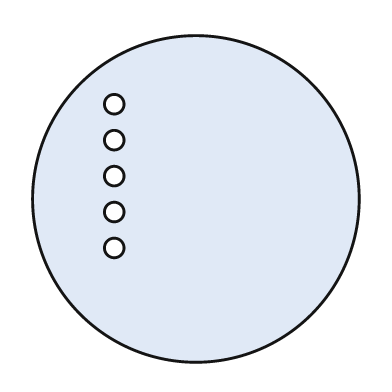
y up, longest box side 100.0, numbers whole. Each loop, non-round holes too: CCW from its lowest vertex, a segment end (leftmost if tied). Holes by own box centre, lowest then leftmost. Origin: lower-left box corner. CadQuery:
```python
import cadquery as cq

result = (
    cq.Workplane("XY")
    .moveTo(50.0, 50.0)
    .circle(50.0)
    .moveTo(25.0, 35.0)
    .circle(3.0)
    .moveTo(25.0, 46.0)
    .circle(3.0)
    .moveTo(25.0, 57.0)
    .circle(3.0)
    .moveTo(25.0, 68.0)
    .circle(3.0)
    .moveTo(25.0, 79.0)
    .circle(3.0)
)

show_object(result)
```